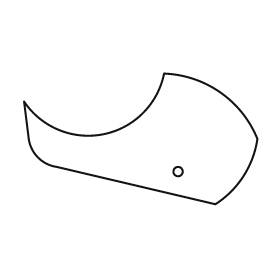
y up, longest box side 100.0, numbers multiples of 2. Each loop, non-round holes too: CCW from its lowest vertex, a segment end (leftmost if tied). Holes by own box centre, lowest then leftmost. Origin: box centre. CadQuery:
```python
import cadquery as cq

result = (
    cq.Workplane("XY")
    .moveTo(32.0, -28.0)
    .threePointArc((44.0, -16.0), (50.0, 0.0))
    .threePointArc((34.0, 20.0), (10.0, 28.0))
    .threePointArc((-16.0, 2.0), (-50.0, 16.0))
    .lineTo(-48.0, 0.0)
    .threePointArc((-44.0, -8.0), (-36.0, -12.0))
    .close()
    .moveTo(16.0, -14.0)
    .circle(2.0)
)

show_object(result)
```